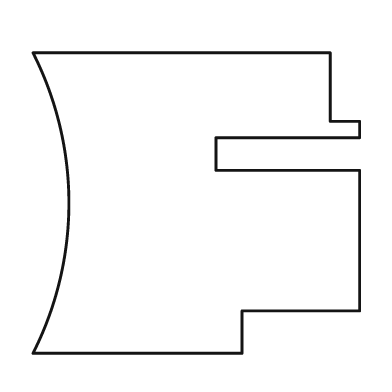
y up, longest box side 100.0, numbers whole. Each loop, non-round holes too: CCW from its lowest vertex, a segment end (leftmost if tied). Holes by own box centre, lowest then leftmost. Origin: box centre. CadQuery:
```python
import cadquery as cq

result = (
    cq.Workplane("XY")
    .moveTo(-50.0, -46.0)
    .lineTo(14.0, -46.0)
    .lineTo(14.0, -33.0)
    .lineTo(50.0, -33.0)
    .lineTo(50.0, 10.0)
    .lineTo(6.0, 10.0)
    .lineTo(6.0, 20.0)
    .lineTo(50.0, 20.0)
    .lineTo(50.0, 25.0)
    .lineTo(41.0, 25.0)
    .lineTo(41.0, 46.0)
    .lineTo(-50.0, 46.0)
    .threePointArc((-39.0, 0.0), (-50.0, -46.0))
    .close()
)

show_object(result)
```